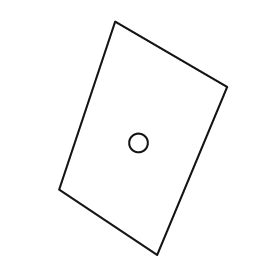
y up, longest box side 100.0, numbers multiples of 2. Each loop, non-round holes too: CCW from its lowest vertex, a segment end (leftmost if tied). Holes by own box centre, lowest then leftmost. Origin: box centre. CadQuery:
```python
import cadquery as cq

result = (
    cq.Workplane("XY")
    .moveTo(6.0, -50.0)
    .lineTo(36.0, 22.0)
    .lineTo(-12.0, 50.0)
    .lineTo(-36.0, -22.0)
    .close()
    .moveTo(-2.0, -2.0)
    .circle(4.0)
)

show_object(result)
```